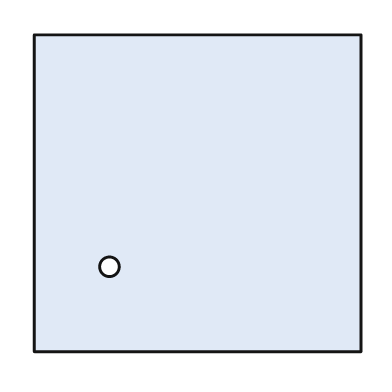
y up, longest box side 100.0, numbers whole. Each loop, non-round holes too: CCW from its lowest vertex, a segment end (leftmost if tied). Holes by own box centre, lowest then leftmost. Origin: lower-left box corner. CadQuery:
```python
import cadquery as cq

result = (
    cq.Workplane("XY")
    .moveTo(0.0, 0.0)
    .lineTo(100.0, 0.0)
    .lineTo(100.0, 97.0)
    .lineTo(0.0, 97.0)
    .close()
    .moveTo(23.0, 26.0)
    .circle(3.0)
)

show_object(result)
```